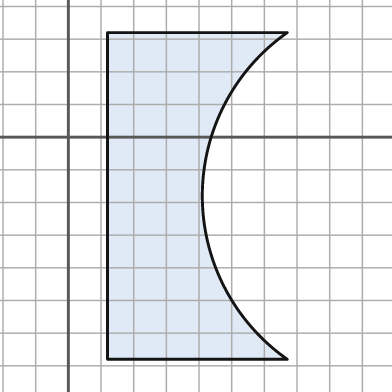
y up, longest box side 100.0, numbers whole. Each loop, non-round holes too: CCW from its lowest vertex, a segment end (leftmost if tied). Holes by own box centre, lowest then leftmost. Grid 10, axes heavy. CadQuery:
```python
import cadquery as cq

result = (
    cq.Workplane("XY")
    .moveTo(12.0, -68.0)
    .lineTo(67.0, -68.0)
    .threePointArc((41.0, -18.0), (67.0, 32.0))
    .lineTo(12.0, 32.0)
    .close()
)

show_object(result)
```